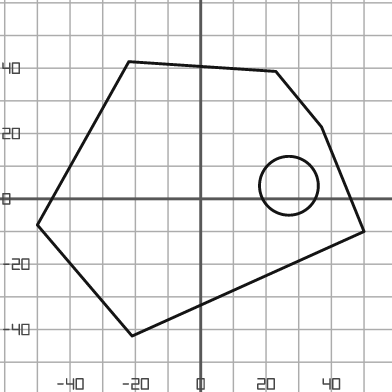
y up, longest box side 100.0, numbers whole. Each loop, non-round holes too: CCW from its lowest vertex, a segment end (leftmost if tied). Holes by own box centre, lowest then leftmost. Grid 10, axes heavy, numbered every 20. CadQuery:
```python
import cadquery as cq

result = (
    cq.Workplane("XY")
    .moveTo(-21.0, -42.0)
    .lineTo(50.0, -10.0)
    .lineTo(37.0, 22.0)
    .lineTo(23.0, 39.0)
    .lineTo(-22.0, 42.0)
    .lineTo(-50.0, -8.0)
    .close()
    .moveTo(27.0, 4.0)
    .circle(9.0)
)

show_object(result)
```